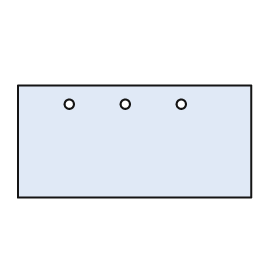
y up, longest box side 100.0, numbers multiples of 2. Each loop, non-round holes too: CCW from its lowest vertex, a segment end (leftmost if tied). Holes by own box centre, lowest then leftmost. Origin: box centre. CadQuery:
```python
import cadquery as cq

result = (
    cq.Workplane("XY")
    .moveTo(-50.0, -24.0)
    .lineTo(50.0, -24.0)
    .lineTo(50.0, 24.0)
    .lineTo(-50.0, 24.0)
    .close()
    .moveTo(-28.0, 16.0)
    .circle(2.0)
    .moveTo(-4.0, 16.0)
    .circle(2.0)
    .moveTo(20.0, 16.0)
    .circle(2.0)
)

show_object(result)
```